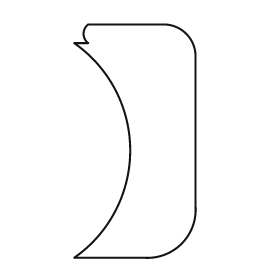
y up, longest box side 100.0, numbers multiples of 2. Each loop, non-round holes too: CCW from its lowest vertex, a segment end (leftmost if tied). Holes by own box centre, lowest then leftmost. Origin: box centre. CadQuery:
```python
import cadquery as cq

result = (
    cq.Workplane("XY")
    .moveTo(-26.0, -50.0)
    .lineTo(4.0, -50.0)
    .threePointArc((20.0, -44.0), (26.0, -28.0))
    .lineTo(26.0, 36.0)
    .threePointArc((22.0, 46.0), (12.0, 50.0))
    .lineTo(-20.0, 50.0)
    .threePointArc((-22.0, 46.0), (-20.0, 42.0))
    .lineTo(-26.0, 42.0)
    .threePointArc((-2.0, -4.0), (-26.0, -50.0))
    .close()
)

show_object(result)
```